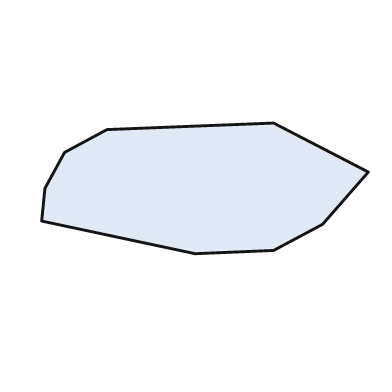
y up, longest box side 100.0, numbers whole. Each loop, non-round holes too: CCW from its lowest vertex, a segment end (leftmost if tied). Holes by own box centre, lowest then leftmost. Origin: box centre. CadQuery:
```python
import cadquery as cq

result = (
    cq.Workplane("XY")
    .moveTo(-3.0, -20.0)
    .lineTo(21.0, -19.0)
    .lineTo(36.0, -11.0)
    .lineTo(50.0, 5.0)
    .lineTo(21.0, 20.0)
    .lineTo(-30.0, 18.0)
    .lineTo(-43.0, 11.0)
    .lineTo(-49.0, 0.0)
    .lineTo(-50.0, -10.0)
    .close()
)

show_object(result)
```